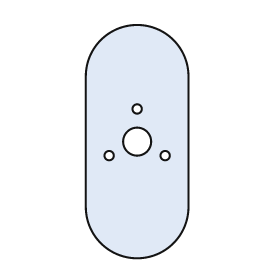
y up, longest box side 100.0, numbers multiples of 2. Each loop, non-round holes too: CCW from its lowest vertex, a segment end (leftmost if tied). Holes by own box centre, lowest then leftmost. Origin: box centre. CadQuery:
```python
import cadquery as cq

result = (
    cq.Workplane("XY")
    .moveTo(-22.0, -28.0)
    .threePointArc((0.0, -50.0), (22.0, -28.0))
    .lineTo(22.0, 28.0)
    .threePointArc((0.0, 50.0), (-22.0, 28.0))
    .close()
    .moveTo(-12.0, -6.0)
    .circle(2.0)
    .moveTo(12.0, -6.0)
    .circle(2.0)
    .moveTo(0.0, 0.0)
    .circle(6.0)
    .moveTo(0.0, 14.0)
    .circle(2.0)
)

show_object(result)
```